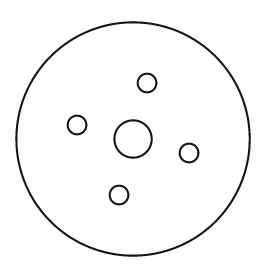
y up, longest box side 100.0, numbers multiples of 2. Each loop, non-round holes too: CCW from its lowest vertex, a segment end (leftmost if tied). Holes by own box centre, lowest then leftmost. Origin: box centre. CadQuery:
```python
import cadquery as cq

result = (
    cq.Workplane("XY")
    .moveTo(0.0, 0.0)
    .circle(50.0)
    .moveTo(-6.0, -24.0)
    .circle(4.0)
    .moveTo(24.0, -6.0)
    .circle(4.0)
    .moveTo(0.0, 0.0)
    .circle(8.0)
    .moveTo(-24.0, 6.0)
    .circle(4.0)
    .moveTo(6.0, 24.0)
    .circle(4.0)
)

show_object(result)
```